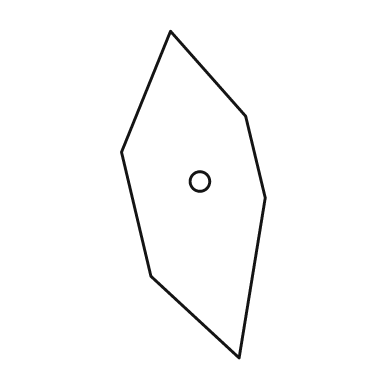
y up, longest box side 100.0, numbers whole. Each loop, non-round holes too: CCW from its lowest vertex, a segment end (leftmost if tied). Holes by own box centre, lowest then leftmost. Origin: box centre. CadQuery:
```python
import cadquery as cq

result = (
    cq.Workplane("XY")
    .moveTo(14.0, -50.0)
    .lineTo(22.0, -1.0)
    .lineTo(16.0, 24.0)
    .lineTo(-7.0, 50.0)
    .lineTo(-22.0, 13.0)
    .lineTo(-13.0, -25.0)
    .close()
    .moveTo(2.0, 4.0)
    .circle(3.0)
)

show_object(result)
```